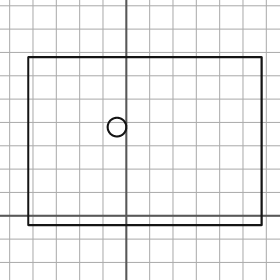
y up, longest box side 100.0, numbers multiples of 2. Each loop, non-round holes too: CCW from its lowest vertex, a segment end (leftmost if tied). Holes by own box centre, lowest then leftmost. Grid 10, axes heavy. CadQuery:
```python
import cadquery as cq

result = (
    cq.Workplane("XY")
    .moveTo(-42.0, -4.0)
    .lineTo(58.0, -4.0)
    .lineTo(58.0, 68.0)
    .lineTo(-42.0, 68.0)
    .close()
    .moveTo(-4.0, 38.0)
    .circle(4.0)
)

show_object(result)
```